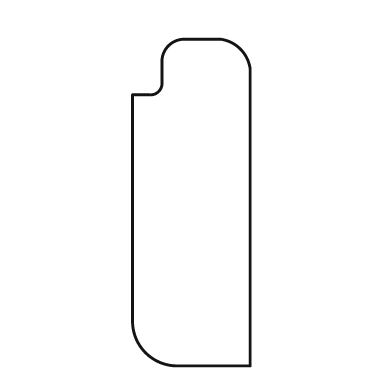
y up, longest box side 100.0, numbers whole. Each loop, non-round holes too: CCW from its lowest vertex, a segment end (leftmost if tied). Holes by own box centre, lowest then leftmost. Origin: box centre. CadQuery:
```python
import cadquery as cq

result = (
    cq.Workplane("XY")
    .moveTo(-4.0, -50.0)
    .lineTo(18.0, -50.0)
    .lineTo(18.0, 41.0)
    .threePointArc((15.0, 47.0), (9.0, 50.0))
    .lineTo(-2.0, 50.0)
    .threePointArc((-7.0, 48.0), (-9.0, 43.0))
    .lineTo(-9.0, 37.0)
    .threePointArc((-10.0, 34.0), (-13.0, 33.0))
    .lineTo(-18.0, 33.0)
    .lineTo(-18.0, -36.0)
    .threePointArc((-14.0, -46.0), (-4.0, -50.0))
    .close()
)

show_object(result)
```